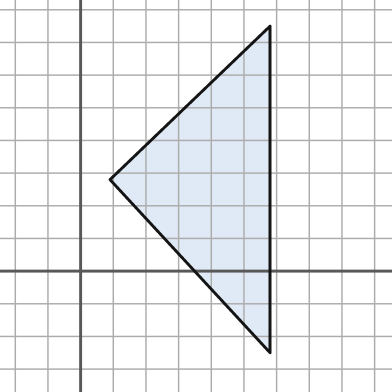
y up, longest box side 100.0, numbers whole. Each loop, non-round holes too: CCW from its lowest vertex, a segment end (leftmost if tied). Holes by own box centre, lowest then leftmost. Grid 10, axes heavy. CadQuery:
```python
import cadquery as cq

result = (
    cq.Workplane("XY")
    .moveTo(58.0, -25.0)
    .lineTo(58.0, 75.0)
    .lineTo(9.0, 28.0)
    .close()
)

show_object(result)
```